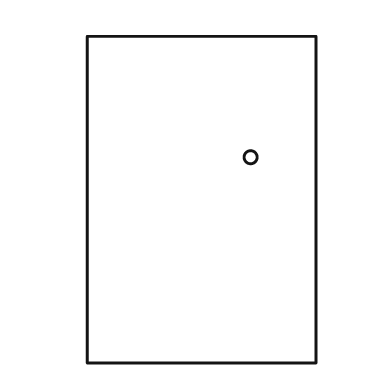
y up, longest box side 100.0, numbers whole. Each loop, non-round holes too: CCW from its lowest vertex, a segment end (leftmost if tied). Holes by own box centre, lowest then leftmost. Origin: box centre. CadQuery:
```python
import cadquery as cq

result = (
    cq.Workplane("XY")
    .moveTo(-35.0, -50.0)
    .lineTo(35.0, -50.0)
    .lineTo(35.0, 50.0)
    .lineTo(-35.0, 50.0)
    .close()
    .moveTo(15.0, 13.0)
    .circle(2.0)
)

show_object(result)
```